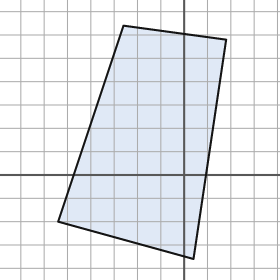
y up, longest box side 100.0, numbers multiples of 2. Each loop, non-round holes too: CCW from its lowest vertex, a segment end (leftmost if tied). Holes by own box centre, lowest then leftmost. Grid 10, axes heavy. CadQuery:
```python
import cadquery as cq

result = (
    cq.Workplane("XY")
    .moveTo(4.0, -36.0)
    .lineTo(18.0, 58.0)
    .lineTo(-26.0, 64.0)
    .lineTo(-54.0, -20.0)
    .close()
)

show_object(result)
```